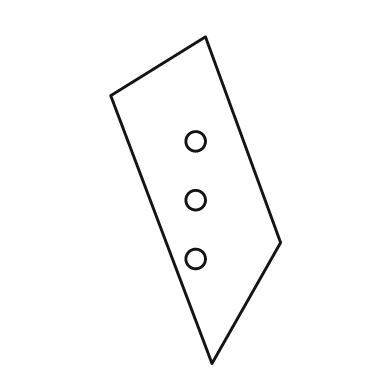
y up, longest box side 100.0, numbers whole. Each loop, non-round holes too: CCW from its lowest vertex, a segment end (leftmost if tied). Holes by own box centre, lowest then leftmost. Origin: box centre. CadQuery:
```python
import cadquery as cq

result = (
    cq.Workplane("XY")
    .moveTo(5.0, -50.0)
    .lineTo(26.0, -13.0)
    .lineTo(3.0, 50.0)
    .lineTo(-26.0, 32.0)
    .close()
    .moveTo(0.0, -18.0)
    .circle(3.0)
    .moveTo(0.0, 0.0)
    .circle(3.0)
    .moveTo(0.0, 18.0)
    .circle(3.0)
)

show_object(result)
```